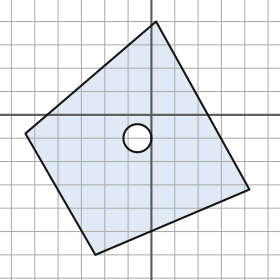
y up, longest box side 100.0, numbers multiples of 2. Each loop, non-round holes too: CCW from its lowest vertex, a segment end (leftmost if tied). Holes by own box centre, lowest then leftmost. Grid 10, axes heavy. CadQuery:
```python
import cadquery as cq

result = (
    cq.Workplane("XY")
    .moveTo(-24.0, -60.0)
    .lineTo(42.0, -32.0)
    .lineTo(2.0, 40.0)
    .lineTo(-54.0, -8.0)
    .close()
    .moveTo(-6.0, -10.0)
    .circle(6.0)
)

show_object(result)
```